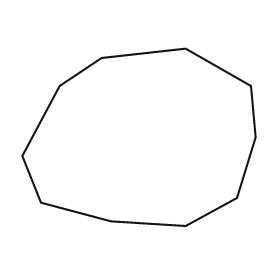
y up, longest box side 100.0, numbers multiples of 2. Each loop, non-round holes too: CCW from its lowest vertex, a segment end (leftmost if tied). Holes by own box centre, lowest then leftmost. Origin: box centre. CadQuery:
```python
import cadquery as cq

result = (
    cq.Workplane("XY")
    .moveTo(20.0, -38.0)
    .lineTo(42.0, -26.0)
    .lineTo(50.0, 0.0)
    .lineTo(48.0, 22.0)
    .lineTo(20.0, 38.0)
    .lineTo(-16.0, 34.0)
    .lineTo(-34.0, 22.0)
    .lineTo(-50.0, -8.0)
    .lineTo(-42.0, -28.0)
    .lineTo(-12.0, -36.0)
    .close()
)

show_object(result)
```